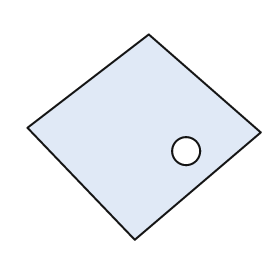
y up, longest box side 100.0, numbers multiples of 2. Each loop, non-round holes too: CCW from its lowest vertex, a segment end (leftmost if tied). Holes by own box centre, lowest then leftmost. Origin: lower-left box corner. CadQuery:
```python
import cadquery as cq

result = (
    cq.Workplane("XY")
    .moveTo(46.0, 0.0)
    .lineTo(100.0, 46.0)
    .lineTo(52.0, 88.0)
    .lineTo(0.0, 48.0)
    .close()
    .moveTo(68.0, 38.0)
    .circle(6.0)
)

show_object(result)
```